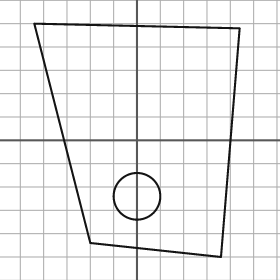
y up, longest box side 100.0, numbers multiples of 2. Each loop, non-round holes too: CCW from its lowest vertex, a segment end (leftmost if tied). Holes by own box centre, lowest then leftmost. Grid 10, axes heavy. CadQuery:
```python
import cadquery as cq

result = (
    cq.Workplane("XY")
    .moveTo(36.0, -50.0)
    .lineTo(44.0, 48.0)
    .lineTo(-44.0, 50.0)
    .lineTo(-20.0, -44.0)
    .close()
    .moveTo(0.0, -24.0)
    .circle(10.0)
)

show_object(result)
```